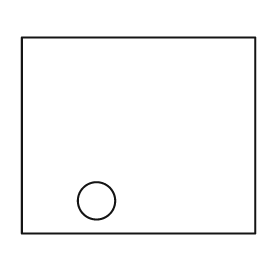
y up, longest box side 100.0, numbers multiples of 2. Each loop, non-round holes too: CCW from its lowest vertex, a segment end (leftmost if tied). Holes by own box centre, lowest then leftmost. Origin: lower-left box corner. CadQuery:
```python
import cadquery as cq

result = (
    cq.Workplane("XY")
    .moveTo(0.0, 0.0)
    .lineTo(100.0, 0.0)
    .lineTo(100.0, 84.0)
    .lineTo(0.0, 84.0)
    .close()
    .moveTo(32.0, 14.0)
    .circle(8.0)
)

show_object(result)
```